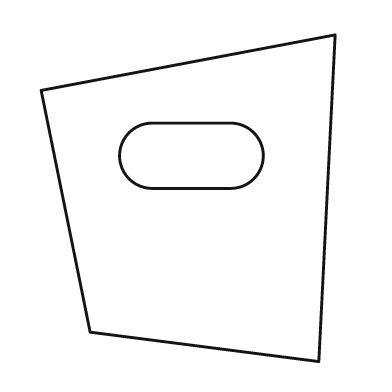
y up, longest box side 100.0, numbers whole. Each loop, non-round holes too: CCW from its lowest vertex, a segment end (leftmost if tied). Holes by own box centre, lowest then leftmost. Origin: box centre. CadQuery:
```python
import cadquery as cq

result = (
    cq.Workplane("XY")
    .moveTo(40.0, -50.0)
    .lineTo(45.0, 50.0)
    .lineTo(-45.0, 33.0)
    .lineTo(-30.0, -41.0)
    .close()
    .moveTo(-11.0, 3.0)
    .lineTo(13.0, 3.0)
    .threePointArc((23.0, 13.0), (13.0, 23.0))
    .lineTo(-11.0, 23.0)
    .threePointArc((-21.0, 13.0), (-11.0, 3.0))
    .close()
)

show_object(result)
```